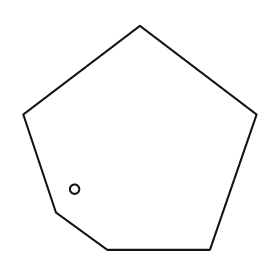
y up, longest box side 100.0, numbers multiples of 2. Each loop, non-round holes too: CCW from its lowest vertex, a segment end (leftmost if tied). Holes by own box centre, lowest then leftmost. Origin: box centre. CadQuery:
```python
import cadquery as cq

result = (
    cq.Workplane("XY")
    .moveTo(-14.0, -48.0)
    .lineTo(30.0, -48.0)
    .lineTo(50.0, 10.0)
    .lineTo(0.0, 48.0)
    .lineTo(-50.0, 10.0)
    .lineTo(-36.0, -32.0)
    .close()
    .moveTo(-28.0, -22.0)
    .circle(2.0)
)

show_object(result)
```